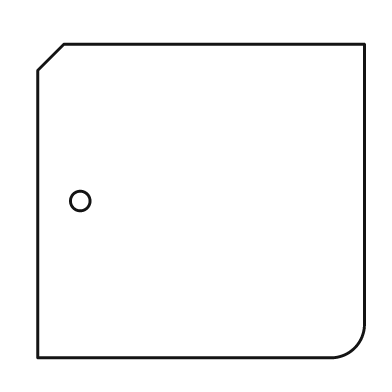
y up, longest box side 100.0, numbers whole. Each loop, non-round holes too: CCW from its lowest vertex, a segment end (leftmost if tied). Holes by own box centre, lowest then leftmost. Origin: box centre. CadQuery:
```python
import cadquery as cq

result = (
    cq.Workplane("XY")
    .moveTo(-50.0, -48.0)
    .lineTo(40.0, -48.0)
    .threePointArc((47.0, -45.0), (50.0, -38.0))
    .lineTo(50.0, 48.0)
    .lineTo(-42.0, 48.0)
    .lineTo(-50.0, 40.0)
    .close()
    .moveTo(-37.0, 0.0)
    .circle(3.0)
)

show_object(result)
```